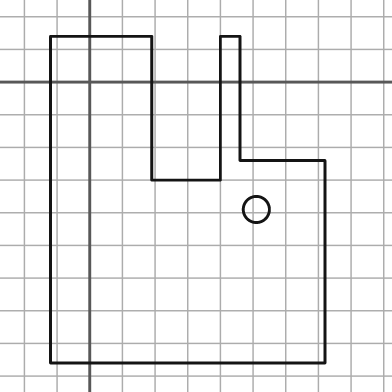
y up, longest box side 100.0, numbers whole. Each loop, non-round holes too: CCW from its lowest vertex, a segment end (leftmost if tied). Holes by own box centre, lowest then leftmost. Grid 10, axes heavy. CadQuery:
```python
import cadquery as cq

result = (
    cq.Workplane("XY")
    .moveTo(-12.0, -86.0)
    .lineTo(72.0, -86.0)
    .lineTo(72.0, -24.0)
    .lineTo(46.0, -24.0)
    .lineTo(46.0, 14.0)
    .lineTo(40.0, 14.0)
    .lineTo(40.0, -30.0)
    .lineTo(19.0, -30.0)
    .lineTo(19.0, 14.0)
    .lineTo(-12.0, 14.0)
    .close()
    .moveTo(51.0, -39.0)
    .circle(4.0)
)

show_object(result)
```